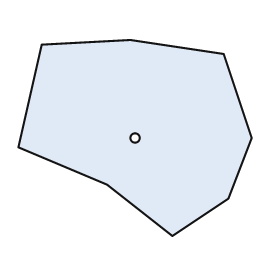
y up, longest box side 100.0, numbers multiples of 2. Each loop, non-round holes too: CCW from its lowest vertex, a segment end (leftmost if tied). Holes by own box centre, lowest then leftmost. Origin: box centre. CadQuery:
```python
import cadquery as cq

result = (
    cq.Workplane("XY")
    .moveTo(16.0, -42.0)
    .lineTo(40.0, -26.0)
    .lineTo(50.0, 0.0)
    .lineTo(38.0, 36.0)
    .lineTo(-2.0, 42.0)
    .lineTo(-40.0, 40.0)
    .lineTo(-50.0, -4.0)
    .lineTo(-12.0, -20.0)
    .close()
    .moveTo(0.0, 0.0)
    .circle(2.0)
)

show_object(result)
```